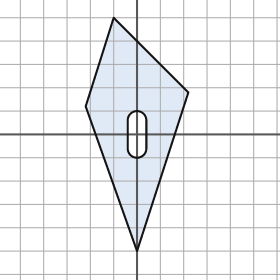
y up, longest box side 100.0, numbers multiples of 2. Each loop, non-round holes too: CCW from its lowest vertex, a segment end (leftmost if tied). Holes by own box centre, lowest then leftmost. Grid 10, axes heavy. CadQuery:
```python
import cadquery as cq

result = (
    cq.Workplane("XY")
    .moveTo(0.0, -50.0)
    .lineTo(22.0, 18.0)
    .lineTo(-10.0, 50.0)
    .lineTo(-22.0, 12.0)
    .close()
    .moveTo(-4.0, -6.0)
    .threePointArc((0.0, -10.0), (4.0, -6.0))
    .lineTo(4.0, 6.0)
    .threePointArc((0.0, 10.0), (-4.0, 6.0))
    .close()
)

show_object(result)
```